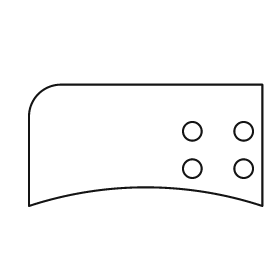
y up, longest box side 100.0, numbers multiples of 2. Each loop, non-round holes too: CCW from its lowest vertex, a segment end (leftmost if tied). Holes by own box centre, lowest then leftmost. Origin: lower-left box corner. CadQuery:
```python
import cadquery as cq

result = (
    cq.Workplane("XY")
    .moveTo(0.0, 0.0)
    .threePointArc((50.0, 8.0), (100.0, 0.0))
    .lineTo(100.0, 52.0)
    .lineTo(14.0, 52.0)
    .threePointArc((4.0, 48.0), (0.0, 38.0))
    .close()
    .moveTo(70.0, 16.0)
    .circle(4.0)
    .moveTo(92.0, 16.0)
    .circle(4.0)
    .moveTo(70.0, 32.0)
    .circle(4.0)
    .moveTo(92.0, 32.0)
    .circle(4.0)
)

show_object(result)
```